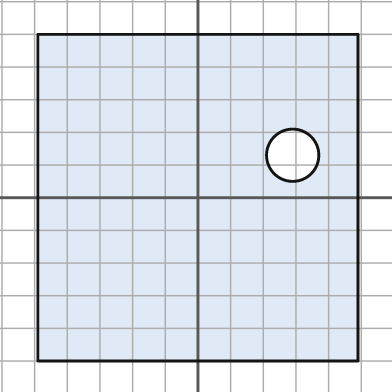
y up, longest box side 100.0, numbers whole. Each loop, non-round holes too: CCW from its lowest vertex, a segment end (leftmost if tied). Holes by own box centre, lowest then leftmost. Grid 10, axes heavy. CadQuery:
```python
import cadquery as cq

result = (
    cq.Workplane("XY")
    .moveTo(-49.0, -50.0)
    .lineTo(49.0, -50.0)
    .lineTo(49.0, 50.0)
    .lineTo(-49.0, 50.0)
    .close()
    .moveTo(29.0, 13.0)
    .circle(8.0)
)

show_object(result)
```